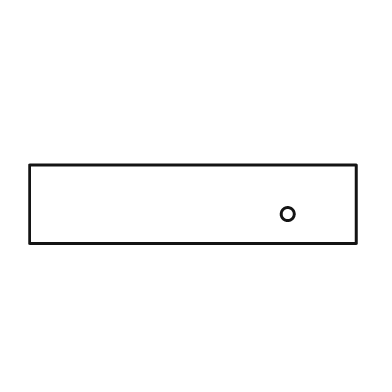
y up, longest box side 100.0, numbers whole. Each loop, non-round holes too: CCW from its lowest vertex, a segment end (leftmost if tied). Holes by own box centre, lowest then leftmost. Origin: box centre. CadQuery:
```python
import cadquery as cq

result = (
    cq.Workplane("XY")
    .moveTo(-50.0, -12.0)
    .lineTo(50.0, -12.0)
    .lineTo(50.0, 12.0)
    .lineTo(-50.0, 12.0)
    .close()
    .moveTo(29.0, -3.0)
    .circle(2.0)
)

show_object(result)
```